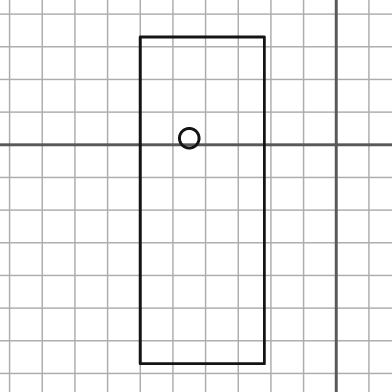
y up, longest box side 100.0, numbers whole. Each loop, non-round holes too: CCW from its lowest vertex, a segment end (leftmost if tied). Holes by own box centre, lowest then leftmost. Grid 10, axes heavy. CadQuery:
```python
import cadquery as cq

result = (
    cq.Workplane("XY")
    .moveTo(-60.0, -67.0)
    .lineTo(-22.0, -67.0)
    .lineTo(-22.0, 33.0)
    .lineTo(-60.0, 33.0)
    .close()
    .moveTo(-45.0, 2.0)
    .circle(3.0)
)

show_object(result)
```